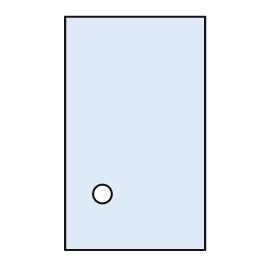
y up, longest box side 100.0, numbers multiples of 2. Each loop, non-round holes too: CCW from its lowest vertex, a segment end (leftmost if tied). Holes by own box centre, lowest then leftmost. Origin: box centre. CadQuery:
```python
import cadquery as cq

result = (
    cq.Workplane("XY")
    .moveTo(-30.0, -50.0)
    .lineTo(30.0, -50.0)
    .lineTo(30.0, 50.0)
    .lineTo(-30.0, 50.0)
    .close()
    .moveTo(-14.0, -26.0)
    .circle(4.0)
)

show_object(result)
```